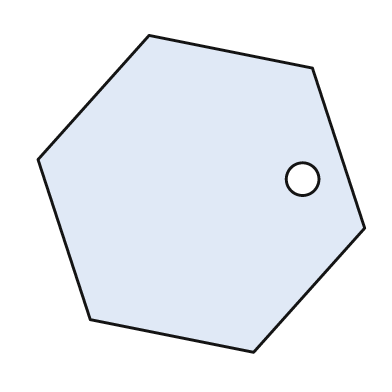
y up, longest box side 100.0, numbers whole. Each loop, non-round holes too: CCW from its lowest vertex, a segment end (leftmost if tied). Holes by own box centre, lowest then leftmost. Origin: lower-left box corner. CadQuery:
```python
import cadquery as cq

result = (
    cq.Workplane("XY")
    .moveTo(66.0, 0.0)
    .lineTo(100.0, 38.0)
    .lineTo(84.0, 87.0)
    .lineTo(34.0, 97.0)
    .lineTo(0.0, 59.0)
    .lineTo(16.0, 10.0)
    .close()
    .moveTo(81.0, 53.0)
    .circle(5.0)
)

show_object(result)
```